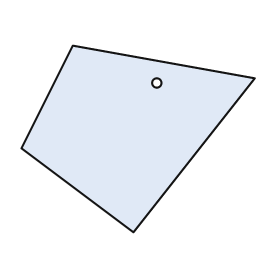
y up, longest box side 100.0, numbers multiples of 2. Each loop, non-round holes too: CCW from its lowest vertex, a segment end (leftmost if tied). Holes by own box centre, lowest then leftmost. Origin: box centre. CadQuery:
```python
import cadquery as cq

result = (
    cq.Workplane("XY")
    .moveTo(-2.0, -40.0)
    .lineTo(50.0, 26.0)
    .lineTo(-28.0, 40.0)
    .lineTo(-50.0, -4.0)
    .close()
    .moveTo(8.0, 24.0)
    .circle(2.0)
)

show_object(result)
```